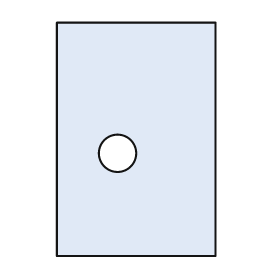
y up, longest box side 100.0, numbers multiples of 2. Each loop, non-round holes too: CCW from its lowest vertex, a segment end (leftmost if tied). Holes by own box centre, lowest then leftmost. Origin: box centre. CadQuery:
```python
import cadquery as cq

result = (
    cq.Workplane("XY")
    .moveTo(-34.0, -50.0)
    .lineTo(34.0, -50.0)
    .lineTo(34.0, 50.0)
    .lineTo(-34.0, 50.0)
    .close()
    .moveTo(-8.0, -6.0)
    .circle(8.0)
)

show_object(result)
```